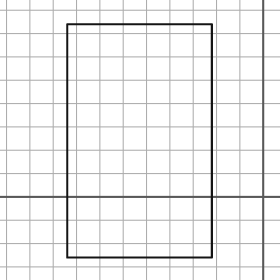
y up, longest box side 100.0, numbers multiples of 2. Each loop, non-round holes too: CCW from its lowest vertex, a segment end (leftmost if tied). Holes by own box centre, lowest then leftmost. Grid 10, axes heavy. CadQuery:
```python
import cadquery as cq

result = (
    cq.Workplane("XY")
    .moveTo(-84.0, -26.0)
    .lineTo(-22.0, -26.0)
    .lineTo(-22.0, 74.0)
    .lineTo(-84.0, 74.0)
    .close()
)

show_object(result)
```